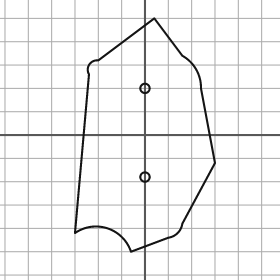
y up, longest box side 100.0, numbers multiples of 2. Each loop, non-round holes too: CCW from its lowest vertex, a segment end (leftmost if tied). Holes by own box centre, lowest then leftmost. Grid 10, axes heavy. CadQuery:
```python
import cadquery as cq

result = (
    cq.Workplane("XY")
    .moveTo(-6.0, -50.0)
    .lineTo(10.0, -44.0)
    .threePointArc((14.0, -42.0), (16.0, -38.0))
    .lineTo(30.0, -12.0)
    .lineTo(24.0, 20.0)
    .threePointArc((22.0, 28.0), (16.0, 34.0))
    .lineTo(4.0, 50.0)
    .lineTo(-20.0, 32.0)
    .threePointArc((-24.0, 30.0), (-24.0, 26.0))
    .lineTo(-30.0, -42.0)
    .threePointArc((-16.0, -40.0), (-6.0, -50.0))
    .close()
    .moveTo(0.0, -18.0)
    .circle(2.0)
    .moveTo(0.0, 20.0)
    .circle(2.0)
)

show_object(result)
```